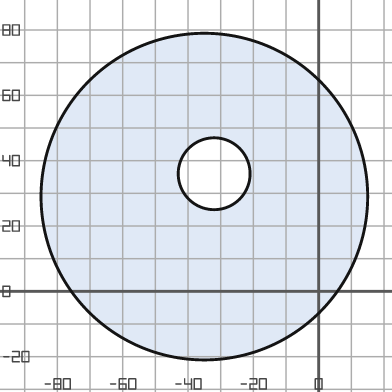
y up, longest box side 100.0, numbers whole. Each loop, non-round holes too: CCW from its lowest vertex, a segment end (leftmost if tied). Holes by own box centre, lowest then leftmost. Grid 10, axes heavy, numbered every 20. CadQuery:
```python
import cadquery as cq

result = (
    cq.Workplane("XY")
    .moveTo(-35.0, 29.0)
    .circle(50.0)
    .moveTo(-32.0, 36.0)
    .circle(11.0)
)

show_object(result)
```